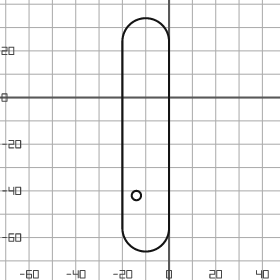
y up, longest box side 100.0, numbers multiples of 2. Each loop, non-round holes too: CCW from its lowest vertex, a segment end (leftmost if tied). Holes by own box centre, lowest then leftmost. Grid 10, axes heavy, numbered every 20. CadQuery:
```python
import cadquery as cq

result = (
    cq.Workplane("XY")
    .moveTo(-20.0, -56.0)
    .threePointArc((-10.0, -66.0), (0.0, -56.0))
    .lineTo(0.0, 24.0)
    .threePointArc((-10.0, 34.0), (-20.0, 24.0))
    .close()
    .moveTo(-14.0, -42.0)
    .circle(2.0)
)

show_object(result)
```